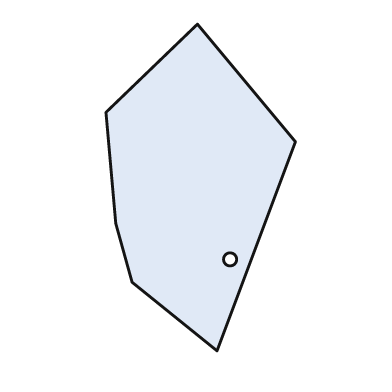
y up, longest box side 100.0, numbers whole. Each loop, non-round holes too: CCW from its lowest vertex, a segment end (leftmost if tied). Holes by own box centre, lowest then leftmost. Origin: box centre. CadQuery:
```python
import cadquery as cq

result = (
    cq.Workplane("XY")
    .moveTo(5.0, -50.0)
    .lineTo(29.0, 14.0)
    .lineTo(-1.0, 50.0)
    .lineTo(-29.0, 23.0)
    .lineTo(-26.0, -11.0)
    .lineTo(-21.0, -29.0)
    .close()
    .moveTo(9.0, -22.0)
    .circle(2.0)
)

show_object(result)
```